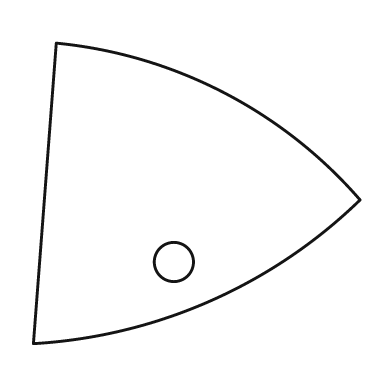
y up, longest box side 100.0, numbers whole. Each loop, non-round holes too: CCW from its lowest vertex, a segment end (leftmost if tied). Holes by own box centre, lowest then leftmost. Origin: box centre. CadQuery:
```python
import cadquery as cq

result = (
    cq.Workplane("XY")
    .moveTo(-50.0, -46.0)
    .threePointArc((4.0, -33.0), (50.0, -2.0))
    .threePointArc((8.0, 31.0), (-43.0, 46.0))
    .close()
    .moveTo(-7.0, -21.0)
    .circle(6.0)
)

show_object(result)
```